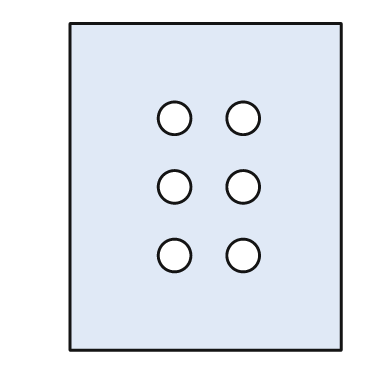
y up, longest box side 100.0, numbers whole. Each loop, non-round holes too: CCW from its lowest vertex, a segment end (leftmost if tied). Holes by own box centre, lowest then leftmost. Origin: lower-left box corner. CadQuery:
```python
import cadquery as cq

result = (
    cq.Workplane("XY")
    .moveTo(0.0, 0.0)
    .lineTo(83.0, 0.0)
    .lineTo(83.0, 100.0)
    .lineTo(0.0, 100.0)
    .close()
    .moveTo(32.0, 29.0)
    .circle(5.0)
    .moveTo(53.0, 29.0)
    .circle(5.0)
    .moveTo(32.0, 50.0)
    .circle(5.0)
    .moveTo(53.0, 50.0)
    .circle(5.0)
    .moveTo(32.0, 71.0)
    .circle(5.0)
    .moveTo(53.0, 71.0)
    .circle(5.0)
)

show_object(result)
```